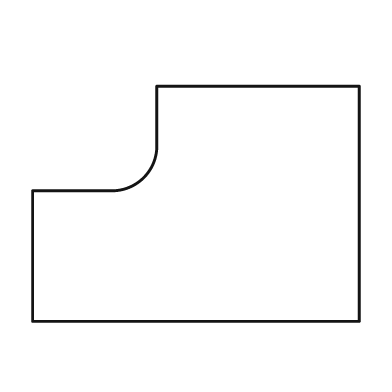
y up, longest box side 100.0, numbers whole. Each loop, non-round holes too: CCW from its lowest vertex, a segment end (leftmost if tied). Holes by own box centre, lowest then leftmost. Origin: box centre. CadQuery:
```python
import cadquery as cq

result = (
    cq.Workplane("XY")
    .moveTo(-50.0, -36.0)
    .lineTo(50.0, -36.0)
    .lineTo(50.0, 36.0)
    .lineTo(-12.0, 36.0)
    .lineTo(-12.0, 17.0)
    .threePointArc((-16.0, 8.0), (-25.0, 4.0))
    .lineTo(-50.0, 4.0)
    .close()
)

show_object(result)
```